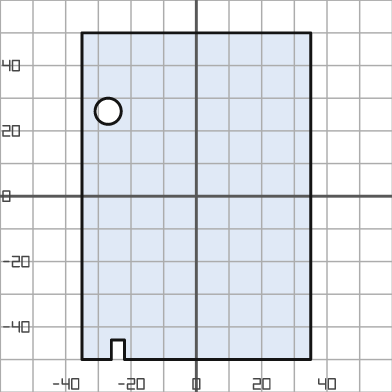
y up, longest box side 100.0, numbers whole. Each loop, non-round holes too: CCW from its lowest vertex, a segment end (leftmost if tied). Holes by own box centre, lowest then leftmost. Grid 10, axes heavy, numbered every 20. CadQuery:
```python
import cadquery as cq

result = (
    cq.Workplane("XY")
    .moveTo(-35.0, -50.0)
    .lineTo(-26.0, -50.0)
    .lineTo(-26.0, -44.0)
    .lineTo(-22.0, -44.0)
    .lineTo(-22.0, -50.0)
    .lineTo(35.0, -50.0)
    .lineTo(35.0, 50.0)
    .lineTo(-35.0, 50.0)
    .close()
    .moveTo(-27.0, 26.0)
    .circle(4.0)
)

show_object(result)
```